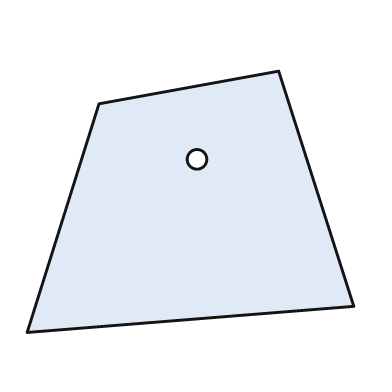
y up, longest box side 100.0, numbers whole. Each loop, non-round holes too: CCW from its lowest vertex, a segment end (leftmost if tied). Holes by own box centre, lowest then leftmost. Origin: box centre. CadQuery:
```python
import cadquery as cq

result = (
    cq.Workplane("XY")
    .moveTo(-50.0, -40.0)
    .lineTo(50.0, -32.0)
    .lineTo(27.0, 40.0)
    .lineTo(-28.0, 30.0)
    .close()
    .moveTo(2.0, 13.0)
    .circle(3.0)
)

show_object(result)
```